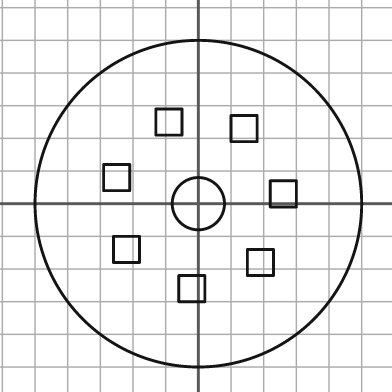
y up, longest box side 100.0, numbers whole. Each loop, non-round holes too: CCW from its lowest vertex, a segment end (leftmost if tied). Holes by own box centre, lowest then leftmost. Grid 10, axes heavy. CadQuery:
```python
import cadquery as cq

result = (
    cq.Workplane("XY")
    .moveTo(0.0, 0.0)
    .circle(50.0)
    .moveTo(-6.0, -30.0)
    .lineTo(2.0, -30.0)
    .lineTo(2.0, -22.0)
    .lineTo(-6.0, -22.0)
    .close()
    .moveTo(15.0, -22.0)
    .lineTo(23.0, -22.0)
    .lineTo(23.0, -14.0)
    .lineTo(15.0, -14.0)
    .close()
    .moveTo(-26.0, -18.0)
    .lineTo(-18.0, -18.0)
    .lineTo(-18.0, -10.0)
    .lineTo(-26.0, -10.0)
    .close()
    .moveTo(0.0, 0.0)
    .circle(8.0)
    .moveTo(22.0, -1.0)
    .lineTo(30.0, -1.0)
    .lineTo(30.0, 7.0)
    .lineTo(22.0, 7.0)
    .close()
    .moveTo(-29.0, 4.0)
    .lineTo(-21.0, 4.0)
    .lineTo(-21.0, 12.0)
    .lineTo(-29.0, 12.0)
    .close()
    .moveTo(10.0, 19.0)
    .lineTo(18.0, 19.0)
    .lineTo(18.0, 27.0)
    .lineTo(10.0, 27.0)
    .close()
    .moveTo(-13.0, 21.0)
    .lineTo(-5.0, 21.0)
    .lineTo(-5.0, 29.0)
    .lineTo(-13.0, 29.0)
    .close()
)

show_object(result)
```